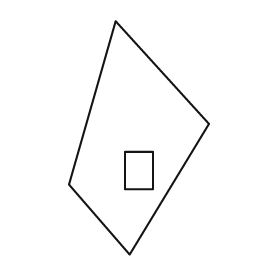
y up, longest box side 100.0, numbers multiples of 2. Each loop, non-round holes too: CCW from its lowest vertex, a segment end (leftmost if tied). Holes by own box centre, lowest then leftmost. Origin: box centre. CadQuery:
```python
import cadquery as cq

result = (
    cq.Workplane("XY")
    .moveTo(-4.0, -50.0)
    .lineTo(30.0, 6.0)
    .lineTo(-10.0, 50.0)
    .lineTo(-30.0, -20.0)
    .close()
    .moveTo(-6.0, -22.0)
    .lineTo(6.0, -22.0)
    .lineTo(6.0, -6.0)
    .lineTo(-6.0, -6.0)
    .close()
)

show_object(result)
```